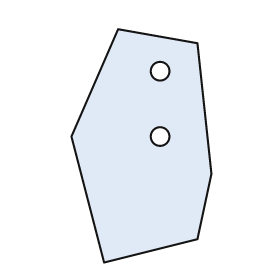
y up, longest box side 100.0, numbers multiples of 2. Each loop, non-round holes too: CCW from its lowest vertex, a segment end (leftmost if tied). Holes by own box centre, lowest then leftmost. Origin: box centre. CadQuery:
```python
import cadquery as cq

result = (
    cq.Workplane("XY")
    .moveTo(-16.0, -50.0)
    .lineTo(24.0, -40.0)
    .lineTo(30.0, -12.0)
    .lineTo(24.0, 44.0)
    .lineTo(-10.0, 50.0)
    .lineTo(-30.0, 4.0)
    .close()
    .moveTo(8.0, 4.0)
    .circle(4.0)
    .moveTo(8.0, 32.0)
    .circle(4.0)
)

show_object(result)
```